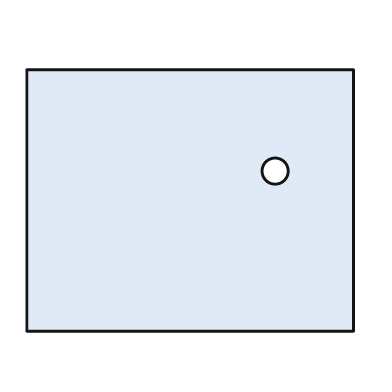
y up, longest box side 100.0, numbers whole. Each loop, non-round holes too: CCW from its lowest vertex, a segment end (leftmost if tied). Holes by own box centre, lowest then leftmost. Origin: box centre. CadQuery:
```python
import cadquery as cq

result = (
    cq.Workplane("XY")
    .moveTo(-50.0, -40.0)
    .lineTo(50.0, -40.0)
    .lineTo(50.0, 40.0)
    .lineTo(-50.0, 40.0)
    .close()
    .moveTo(26.0, 9.0)
    .circle(4.0)
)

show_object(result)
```